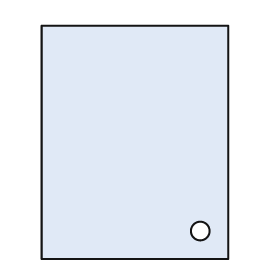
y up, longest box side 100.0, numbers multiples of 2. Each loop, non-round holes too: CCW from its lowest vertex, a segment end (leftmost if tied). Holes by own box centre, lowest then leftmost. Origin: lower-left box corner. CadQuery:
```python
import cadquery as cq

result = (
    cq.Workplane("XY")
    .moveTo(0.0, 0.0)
    .lineTo(80.0, 0.0)
    .lineTo(80.0, 100.0)
    .lineTo(0.0, 100.0)
    .close()
    .moveTo(68.0, 12.0)
    .circle(4.0)
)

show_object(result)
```